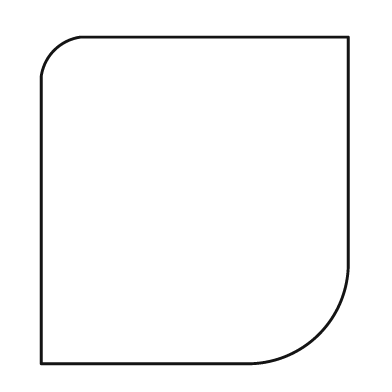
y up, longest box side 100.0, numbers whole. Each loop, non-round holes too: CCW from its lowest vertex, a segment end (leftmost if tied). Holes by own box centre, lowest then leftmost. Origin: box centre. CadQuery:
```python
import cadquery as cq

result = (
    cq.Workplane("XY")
    .moveTo(-47.0, -50.0)
    .lineTo(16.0, -50.0)
    .threePointArc((38.0, -41.0), (47.0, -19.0))
    .lineTo(47.0, 50.0)
    .lineTo(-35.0, 50.0)
    .threePointArc((-43.0, 46.0), (-47.0, 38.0))
    .close()
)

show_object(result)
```